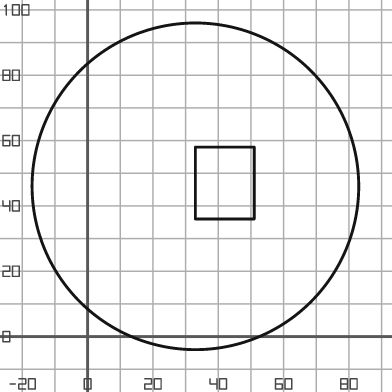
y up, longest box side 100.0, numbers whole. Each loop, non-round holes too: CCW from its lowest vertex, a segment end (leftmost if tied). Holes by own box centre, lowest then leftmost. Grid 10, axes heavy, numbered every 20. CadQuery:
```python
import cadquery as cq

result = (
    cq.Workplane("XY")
    .moveTo(33.0, 46.0)
    .circle(50.0)
    .moveTo(33.0, 36.0)
    .lineTo(51.0, 36.0)
    .lineTo(51.0, 58.0)
    .lineTo(33.0, 58.0)
    .close()
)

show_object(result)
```